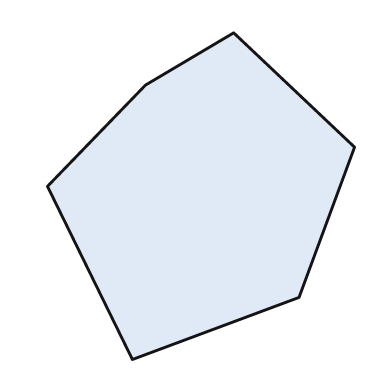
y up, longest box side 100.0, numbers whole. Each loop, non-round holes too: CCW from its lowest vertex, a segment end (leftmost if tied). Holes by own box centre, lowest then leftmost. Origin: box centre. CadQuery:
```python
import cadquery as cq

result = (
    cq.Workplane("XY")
    .moveTo(-21.0, -50.0)
    .lineTo(30.0, -31.0)
    .lineTo(47.0, 15.0)
    .lineTo(10.0, 50.0)
    .lineTo(-17.0, 34.0)
    .lineTo(-47.0, 3.0)
    .close()
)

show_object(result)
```